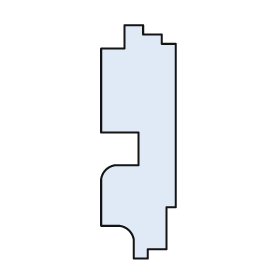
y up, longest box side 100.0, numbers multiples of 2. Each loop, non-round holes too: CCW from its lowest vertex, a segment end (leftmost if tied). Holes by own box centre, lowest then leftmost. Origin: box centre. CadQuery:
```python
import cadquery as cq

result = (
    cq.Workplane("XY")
    .moveTo(-2.0, -50.0)
    .lineTo(4.0, -50.0)
    .lineTo(4.0, -46.0)
    .lineTo(12.0, -46.0)
    .lineTo(12.0, -28.0)
    .lineTo(16.0, -28.0)
    .lineTo(16.0, 42.0)
    .lineTo(10.0, 42.0)
    .lineTo(10.0, 46.0)
    .lineTo(2.0, 46.0)
    .lineTo(2.0, 50.0)
    .lineTo(-6.0, 50.0)
    .lineTo(-6.0, 40.0)
    .lineTo(-16.0, 40.0)
    .lineTo(-16.0, 4.0)
    .lineTo(0.0, 4.0)
    .lineTo(0.0, -10.0)
    .lineTo(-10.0, -10.0)
    .threePointArc((-14.0, -12.0), (-16.0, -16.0))
    .lineTo(-16.0, -36.0)
    .lineTo(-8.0, -36.0)
    .threePointArc((-4.0, -38.0), (-2.0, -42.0))
    .close()
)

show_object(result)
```